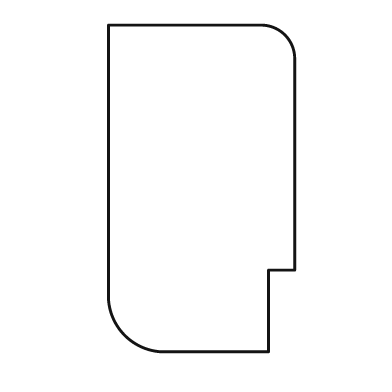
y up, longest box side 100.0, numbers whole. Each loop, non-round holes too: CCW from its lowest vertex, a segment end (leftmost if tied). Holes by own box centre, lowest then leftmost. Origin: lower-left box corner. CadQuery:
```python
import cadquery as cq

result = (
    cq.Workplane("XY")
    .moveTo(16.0, 0.0)
    .lineTo(49.0, 0.0)
    .lineTo(49.0, 25.0)
    .lineTo(57.0, 25.0)
    .lineTo(57.0, 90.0)
    .threePointArc((54.0, 97.0), (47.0, 100.0))
    .lineTo(0.0, 100.0)
    .lineTo(0.0, 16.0)
    .threePointArc((5.0, 5.0), (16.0, 0.0))
    .close()
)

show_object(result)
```